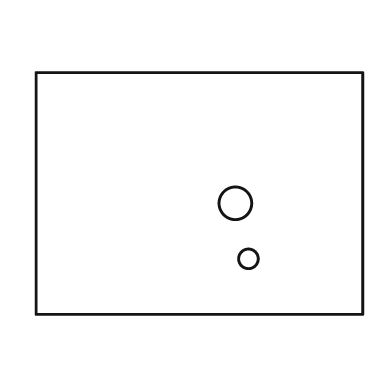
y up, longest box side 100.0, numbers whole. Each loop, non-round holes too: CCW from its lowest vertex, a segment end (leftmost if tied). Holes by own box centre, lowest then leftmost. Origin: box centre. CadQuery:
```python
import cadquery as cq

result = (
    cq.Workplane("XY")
    .moveTo(-50.0, -37.0)
    .lineTo(50.0, -37.0)
    .lineTo(50.0, 37.0)
    .lineTo(-50.0, 37.0)
    .close()
    .moveTo(15.0, -20.0)
    .circle(3.0)
    .moveTo(11.0, -3.0)
    .circle(5.0)
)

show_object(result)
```